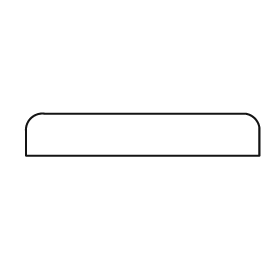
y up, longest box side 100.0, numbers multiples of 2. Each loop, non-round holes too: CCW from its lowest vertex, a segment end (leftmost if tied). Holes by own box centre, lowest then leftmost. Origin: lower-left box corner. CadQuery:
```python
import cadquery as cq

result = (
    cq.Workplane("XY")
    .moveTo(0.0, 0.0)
    .lineTo(100.0, 0.0)
    .lineTo(100.0, 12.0)
    .threePointArc((98.0, 16.0), (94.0, 18.0))
    .lineTo(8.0, 18.0)
    .threePointArc((2.0, 16.0), (0.0, 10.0))
    .close()
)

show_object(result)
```